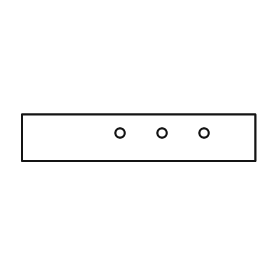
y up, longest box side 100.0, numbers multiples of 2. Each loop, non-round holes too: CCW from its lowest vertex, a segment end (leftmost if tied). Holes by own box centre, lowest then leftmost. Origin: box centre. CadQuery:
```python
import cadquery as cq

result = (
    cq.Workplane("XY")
    .moveTo(-50.0, -10.0)
    .lineTo(50.0, -10.0)
    .lineTo(50.0, 10.0)
    .lineTo(-50.0, 10.0)
    .close()
    .moveTo(-8.0, 2.0)
    .circle(2.0)
    .moveTo(10.0, 2.0)
    .circle(2.0)
    .moveTo(28.0, 2.0)
    .circle(2.0)
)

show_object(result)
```